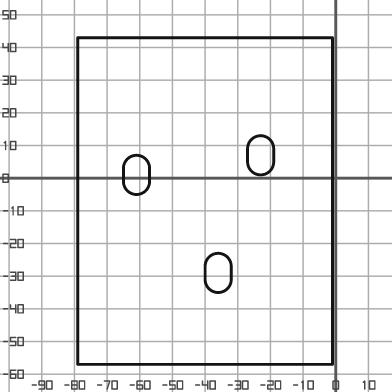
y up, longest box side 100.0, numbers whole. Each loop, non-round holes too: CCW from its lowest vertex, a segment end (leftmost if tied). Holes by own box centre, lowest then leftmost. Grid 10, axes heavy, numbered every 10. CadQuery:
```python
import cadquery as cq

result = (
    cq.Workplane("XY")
    .moveTo(-79.0, -57.0)
    .lineTo(-1.0, -57.0)
    .lineTo(-1.0, 43.0)
    .lineTo(-79.0, 43.0)
    .close()
    .moveTo(-40.0, -31.0)
    .threePointArc((-36.0, -35.0), (-32.0, -31.0))
    .lineTo(-32.0, -27.0)
    .threePointArc((-36.0, -23.0), (-40.0, -27.0))
    .close()
    .moveTo(-65.0, -1.0)
    .threePointArc((-61.0, -5.0), (-57.0, -1.0))
    .lineTo(-57.0, 3.0)
    .threePointArc((-61.0, 7.0), (-65.0, 3.0))
    .close()
    .moveTo(-27.0, 5.0)
    .threePointArc((-23.0, 1.0), (-19.0, 5.0))
    .lineTo(-19.0, 9.0)
    .threePointArc((-23.0, 13.0), (-27.0, 9.0))
    .close()
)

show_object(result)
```